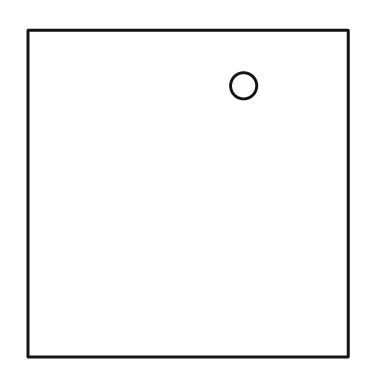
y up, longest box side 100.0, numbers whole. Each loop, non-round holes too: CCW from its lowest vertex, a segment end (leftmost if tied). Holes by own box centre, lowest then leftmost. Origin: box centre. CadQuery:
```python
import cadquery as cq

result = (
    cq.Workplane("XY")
    .moveTo(-49.0, -50.0)
    .lineTo(49.0, -50.0)
    .lineTo(49.0, 50.0)
    .lineTo(-49.0, 50.0)
    .close()
    .moveTo(17.0, 33.0)
    .circle(4.0)
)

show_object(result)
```